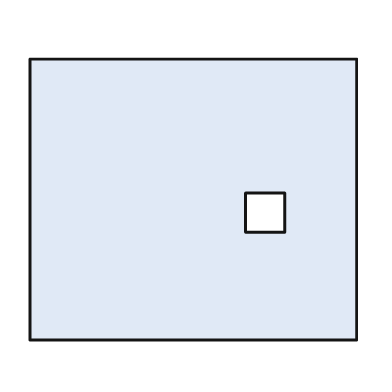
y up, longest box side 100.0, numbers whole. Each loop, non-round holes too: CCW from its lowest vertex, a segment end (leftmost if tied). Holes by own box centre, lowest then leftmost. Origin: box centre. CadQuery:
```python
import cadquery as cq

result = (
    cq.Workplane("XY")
    .moveTo(-50.0, -43.0)
    .lineTo(50.0, -43.0)
    .lineTo(50.0, 43.0)
    .lineTo(-50.0, 43.0)
    .close()
    .moveTo(16.0, -10.0)
    .lineTo(28.0, -10.0)
    .lineTo(28.0, 2.0)
    .lineTo(16.0, 2.0)
    .close()
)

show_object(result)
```